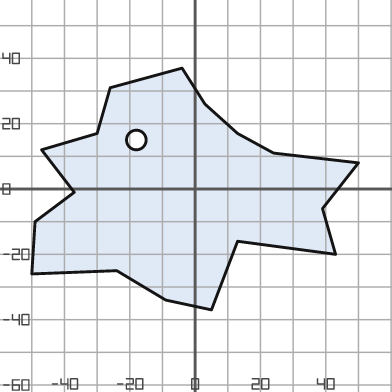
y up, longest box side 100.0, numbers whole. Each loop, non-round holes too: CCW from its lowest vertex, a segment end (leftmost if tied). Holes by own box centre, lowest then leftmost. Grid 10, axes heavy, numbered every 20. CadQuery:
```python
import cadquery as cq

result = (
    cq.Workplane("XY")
    .moveTo(5.0, -37.0)
    .lineTo(13.0, -16.0)
    .lineTo(43.0, -20.0)
    .lineTo(39.0, -6.0)
    .lineTo(50.0, 8.0)
    .lineTo(24.0, 11.0)
    .lineTo(13.0, 17.0)
    .lineTo(3.0, 26.0)
    .lineTo(-4.0, 37.0)
    .lineTo(-26.0, 31.0)
    .lineTo(-30.0, 17.0)
    .lineTo(-47.0, 12.0)
    .lineTo(-37.0, -1.0)
    .lineTo(-49.0, -10.0)
    .lineTo(-50.0, -26.0)
    .lineTo(-24.0, -25.0)
    .lineTo(-9.0, -34.0)
    .close()
    .moveTo(-18.0, 15.0)
    .circle(3.0)
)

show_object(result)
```